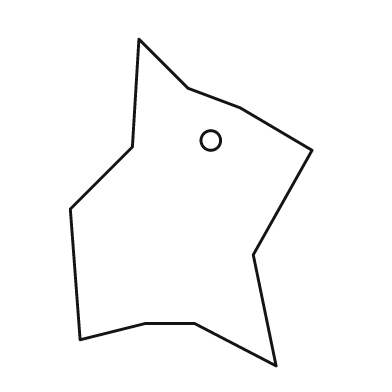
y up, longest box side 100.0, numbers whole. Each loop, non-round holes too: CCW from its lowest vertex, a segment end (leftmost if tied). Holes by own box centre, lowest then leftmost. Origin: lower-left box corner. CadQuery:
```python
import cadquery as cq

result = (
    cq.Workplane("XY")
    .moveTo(63.0, 0.0)
    .lineTo(56.0, 34.0)
    .lineTo(74.0, 66.0)
    .lineTo(52.0, 79.0)
    .lineTo(36.0, 85.0)
    .lineTo(21.0, 100.0)
    .lineTo(19.0, 67.0)
    .lineTo(0.0, 48.0)
    .lineTo(3.0, 8.0)
    .lineTo(23.0, 13.0)
    .lineTo(38.0, 13.0)
    .close()
    .moveTo(43.0, 69.0)
    .circle(3.0)
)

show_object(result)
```